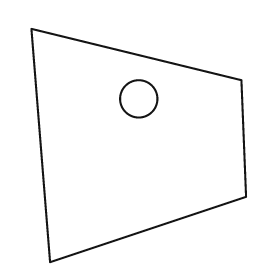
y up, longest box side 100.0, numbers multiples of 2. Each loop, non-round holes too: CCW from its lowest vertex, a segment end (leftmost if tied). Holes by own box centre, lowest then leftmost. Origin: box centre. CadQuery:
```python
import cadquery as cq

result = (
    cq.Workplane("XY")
    .moveTo(-38.0, -50.0)
    .lineTo(46.0, -22.0)
    .lineTo(44.0, 28.0)
    .lineTo(-46.0, 50.0)
    .close()
    .moveTo(0.0, 20.0)
    .circle(8.0)
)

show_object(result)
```